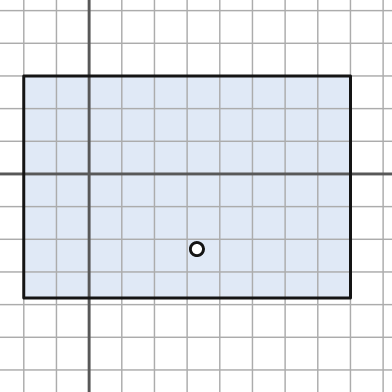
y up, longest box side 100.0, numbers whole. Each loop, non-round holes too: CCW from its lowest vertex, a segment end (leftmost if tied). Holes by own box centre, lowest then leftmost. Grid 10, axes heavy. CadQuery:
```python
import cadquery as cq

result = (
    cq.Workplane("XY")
    .moveTo(-20.0, -38.0)
    .lineTo(80.0, -38.0)
    .lineTo(80.0, 30.0)
    .lineTo(-20.0, 30.0)
    .close()
    .moveTo(33.0, -23.0)
    .circle(2.0)
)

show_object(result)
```